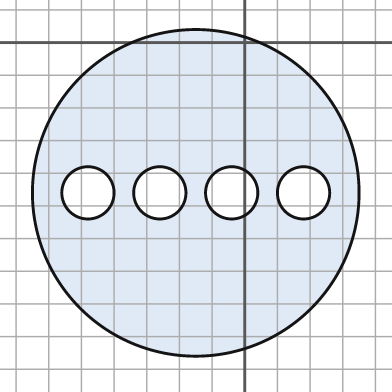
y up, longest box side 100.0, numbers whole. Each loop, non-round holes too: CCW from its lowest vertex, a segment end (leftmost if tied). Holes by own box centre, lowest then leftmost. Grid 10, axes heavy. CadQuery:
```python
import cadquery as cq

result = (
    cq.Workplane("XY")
    .moveTo(-15.0, -46.0)
    .circle(50.0)
    .moveTo(-48.0, -46.0)
    .circle(8.0)
    .moveTo(-26.0, -46.0)
    .circle(8.0)
    .moveTo(-4.0, -46.0)
    .circle(8.0)
    .moveTo(18.0, -46.0)
    .circle(8.0)
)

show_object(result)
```